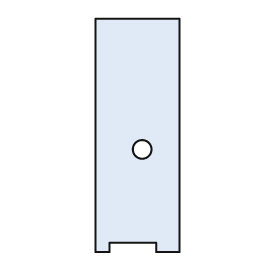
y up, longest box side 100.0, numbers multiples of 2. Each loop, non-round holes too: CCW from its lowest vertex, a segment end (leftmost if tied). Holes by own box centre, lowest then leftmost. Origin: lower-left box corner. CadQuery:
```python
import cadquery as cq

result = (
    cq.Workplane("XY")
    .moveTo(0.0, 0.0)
    .lineTo(6.0, 0.0)
    .lineTo(6.0, 4.0)
    .lineTo(26.0, 4.0)
    .lineTo(26.0, 0.0)
    .lineTo(36.0, 0.0)
    .lineTo(36.0, 100.0)
    .lineTo(0.0, 100.0)
    .close()
    .moveTo(20.0, 44.0)
    .circle(4.0)
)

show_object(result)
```